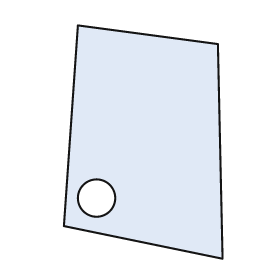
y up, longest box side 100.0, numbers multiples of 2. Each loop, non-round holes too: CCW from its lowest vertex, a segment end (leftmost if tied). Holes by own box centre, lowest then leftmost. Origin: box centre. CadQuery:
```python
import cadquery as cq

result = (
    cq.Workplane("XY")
    .moveTo(34.0, -50.0)
    .lineTo(32.0, 42.0)
    .lineTo(-28.0, 50.0)
    .lineTo(-34.0, -36.0)
    .close()
    .moveTo(-20.0, -24.0)
    .circle(8.0)
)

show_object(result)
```